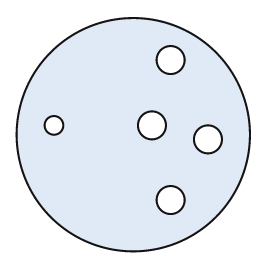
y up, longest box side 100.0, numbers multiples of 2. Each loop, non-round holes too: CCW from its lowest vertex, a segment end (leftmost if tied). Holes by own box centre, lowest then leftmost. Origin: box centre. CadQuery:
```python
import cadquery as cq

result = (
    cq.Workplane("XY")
    .moveTo(0.0, 0.0)
    .circle(50.0)
    .moveTo(16.0, -28.0)
    .circle(6.0)
    .moveTo(32.0, -2.0)
    .circle(6.0)
    .moveTo(-34.0, 4.0)
    .circle(4.0)
    .moveTo(8.0, 4.0)
    .circle(6.0)
    .moveTo(16.0, 32.0)
    .circle(6.0)
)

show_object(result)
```